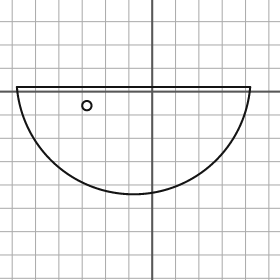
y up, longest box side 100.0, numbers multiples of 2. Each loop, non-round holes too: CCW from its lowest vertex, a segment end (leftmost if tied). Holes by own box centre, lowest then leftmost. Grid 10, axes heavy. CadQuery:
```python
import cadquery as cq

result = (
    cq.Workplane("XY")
    .moveTo(-58.0, 2.0)
    .threePointArc((-8.0, -44.0), (42.0, 2.0))
    .close()
    .moveTo(-28.0, -6.0)
    .circle(2.0)
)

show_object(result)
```